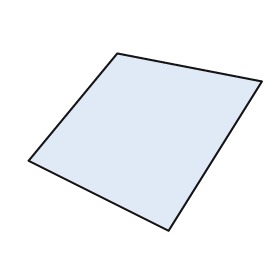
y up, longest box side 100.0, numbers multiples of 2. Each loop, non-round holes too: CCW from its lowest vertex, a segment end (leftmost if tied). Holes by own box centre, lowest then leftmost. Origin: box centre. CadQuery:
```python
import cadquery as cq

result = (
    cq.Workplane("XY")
    .moveTo(10.0, -38.0)
    .lineTo(50.0, 26.0)
    .lineTo(-12.0, 38.0)
    .lineTo(-50.0, -8.0)
    .close()
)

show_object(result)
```